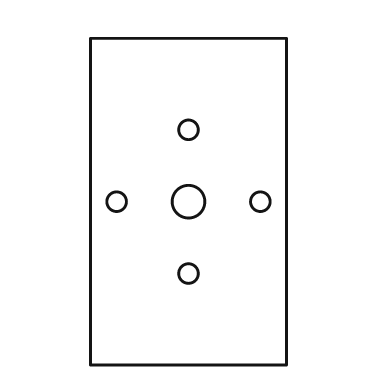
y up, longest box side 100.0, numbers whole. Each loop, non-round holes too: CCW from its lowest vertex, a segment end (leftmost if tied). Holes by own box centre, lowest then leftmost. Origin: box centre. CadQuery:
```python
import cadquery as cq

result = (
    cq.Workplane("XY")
    .moveTo(-30.0, -50.0)
    .lineTo(30.0, -50.0)
    .lineTo(30.0, 50.0)
    .lineTo(-30.0, 50.0)
    .close()
    .moveTo(0.0, -22.0)
    .circle(3.0)
    .moveTo(-22.0, 0.0)
    .circle(3.0)
    .moveTo(0.0, 0.0)
    .circle(5.0)
    .moveTo(22.0, 0.0)
    .circle(3.0)
    .moveTo(0.0, 22.0)
    .circle(3.0)
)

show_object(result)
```